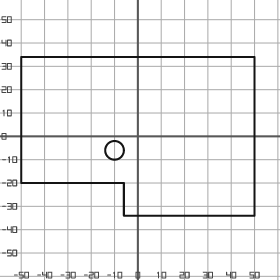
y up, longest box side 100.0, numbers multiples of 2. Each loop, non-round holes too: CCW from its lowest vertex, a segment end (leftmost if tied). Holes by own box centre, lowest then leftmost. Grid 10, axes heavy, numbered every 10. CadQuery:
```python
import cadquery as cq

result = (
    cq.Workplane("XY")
    .moveTo(-6.0, -34.0)
    .lineTo(50.0, -34.0)
    .lineTo(50.0, 34.0)
    .lineTo(-50.0, 34.0)
    .lineTo(-50.0, -20.0)
    .lineTo(-6.0, -20.0)
    .close()
    .moveTo(-10.0, -6.0)
    .circle(4.0)
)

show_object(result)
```